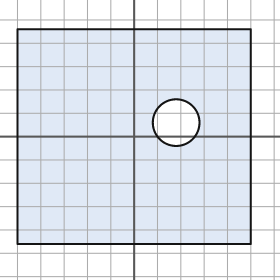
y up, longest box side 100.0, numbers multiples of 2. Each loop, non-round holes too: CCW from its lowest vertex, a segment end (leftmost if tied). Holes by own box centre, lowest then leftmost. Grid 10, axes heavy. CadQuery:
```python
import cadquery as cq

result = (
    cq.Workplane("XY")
    .moveTo(-50.0, -46.0)
    .lineTo(50.0, -46.0)
    .lineTo(50.0, 46.0)
    .lineTo(-50.0, 46.0)
    .close()
    .moveTo(18.0, 6.0)
    .circle(10.0)
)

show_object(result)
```